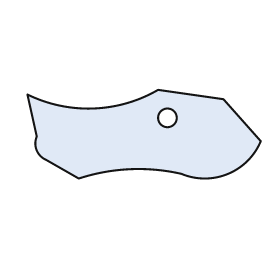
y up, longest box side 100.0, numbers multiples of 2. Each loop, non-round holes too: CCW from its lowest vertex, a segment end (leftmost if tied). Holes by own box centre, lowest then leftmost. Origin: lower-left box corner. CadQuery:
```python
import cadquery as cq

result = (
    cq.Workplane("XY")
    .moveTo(22.0, 0.0)
    .threePointArc((44.0, 4.0), (66.0, 2.0))
    .threePointArc((86.0, 2.0), (100.0, 16.0))
    .lineTo(84.0, 34.0)
    .lineTo(56.0, 38.0)
    .threePointArc((28.0, 30.0), (0.0, 36.0))
    .lineTo(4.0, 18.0)
    .threePointArc((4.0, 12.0), (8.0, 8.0))
    .close()
    .moveTo(60.0, 26.0)
    .circle(4.0)
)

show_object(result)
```